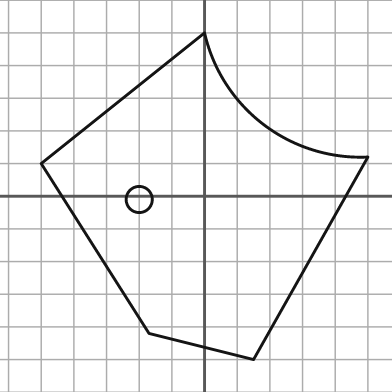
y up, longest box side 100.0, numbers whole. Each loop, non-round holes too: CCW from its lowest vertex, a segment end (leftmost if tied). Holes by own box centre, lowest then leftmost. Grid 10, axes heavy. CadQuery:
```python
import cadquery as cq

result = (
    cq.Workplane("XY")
    .moveTo(15.0, -50.0)
    .lineTo(50.0, 12.0)
    .threePointArc((18.0, 22.0), (0.0, 50.0))
    .lineTo(-50.0, 10.0)
    .lineTo(-17.0, -42.0)
    .close()
    .moveTo(-20.0, -1.0)
    .circle(4.0)
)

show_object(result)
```